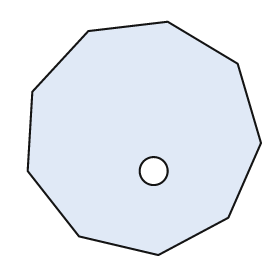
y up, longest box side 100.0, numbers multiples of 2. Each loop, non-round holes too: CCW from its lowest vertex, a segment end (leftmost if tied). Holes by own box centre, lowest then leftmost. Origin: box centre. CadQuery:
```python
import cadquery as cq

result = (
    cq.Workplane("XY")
    .moveTo(6.0, -50.0)
    .lineTo(36.0, -34.0)
    .lineTo(50.0, -2.0)
    .lineTo(40.0, 32.0)
    .lineTo(10.0, 50.0)
    .lineTo(-24.0, 46.0)
    .lineTo(-48.0, 20.0)
    .lineTo(-50.0, -14.0)
    .lineTo(-28.0, -42.0)
    .close()
    .moveTo(4.0, -14.0)
    .circle(6.0)
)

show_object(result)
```